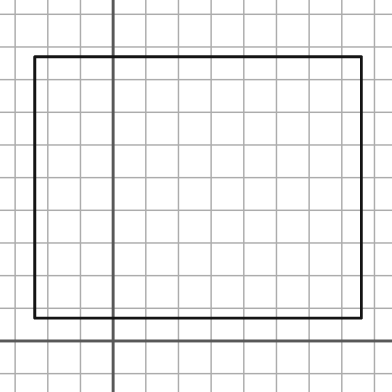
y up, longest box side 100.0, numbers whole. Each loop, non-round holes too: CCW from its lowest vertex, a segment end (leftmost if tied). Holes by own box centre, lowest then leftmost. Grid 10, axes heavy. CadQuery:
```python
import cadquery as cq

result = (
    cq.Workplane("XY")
    .moveTo(-24.0, 7.0)
    .lineTo(76.0, 7.0)
    .lineTo(76.0, 87.0)
    .lineTo(-24.0, 87.0)
    .close()
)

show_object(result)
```